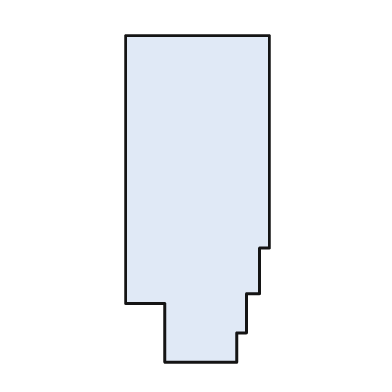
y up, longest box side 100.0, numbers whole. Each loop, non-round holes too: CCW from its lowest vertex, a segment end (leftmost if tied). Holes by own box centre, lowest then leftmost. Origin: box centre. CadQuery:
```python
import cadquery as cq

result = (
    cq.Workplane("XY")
    .moveTo(-10.0, -50.0)
    .lineTo(12.0, -50.0)
    .lineTo(12.0, -41.0)
    .lineTo(15.0, -41.0)
    .lineTo(15.0, -29.0)
    .lineTo(19.0, -29.0)
    .lineTo(19.0, -15.0)
    .lineTo(22.0, -15.0)
    .lineTo(22.0, 50.0)
    .lineTo(-22.0, 50.0)
    .lineTo(-22.0, -32.0)
    .lineTo(-10.0, -32.0)
    .close()
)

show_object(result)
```